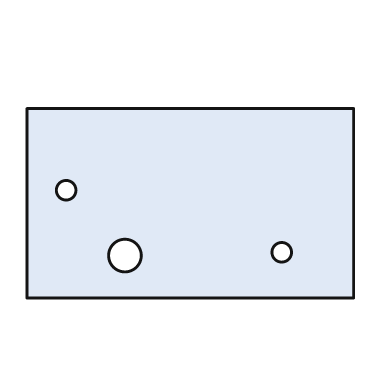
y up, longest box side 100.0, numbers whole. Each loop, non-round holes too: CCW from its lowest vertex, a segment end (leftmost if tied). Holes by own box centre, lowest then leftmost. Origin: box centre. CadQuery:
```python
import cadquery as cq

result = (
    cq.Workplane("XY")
    .moveTo(-50.0, -29.0)
    .lineTo(50.0, -29.0)
    .lineTo(50.0, 29.0)
    .lineTo(-50.0, 29.0)
    .close()
    .moveTo(-20.0, -16.0)
    .circle(5.0)
    .moveTo(28.0, -15.0)
    .circle(3.0)
    .moveTo(-38.0, 4.0)
    .circle(3.0)
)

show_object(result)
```